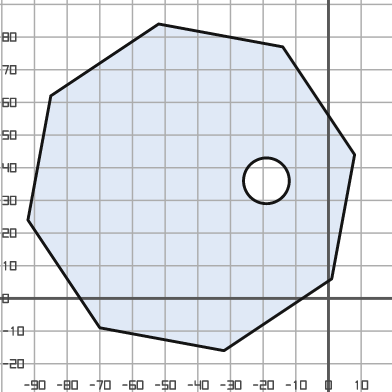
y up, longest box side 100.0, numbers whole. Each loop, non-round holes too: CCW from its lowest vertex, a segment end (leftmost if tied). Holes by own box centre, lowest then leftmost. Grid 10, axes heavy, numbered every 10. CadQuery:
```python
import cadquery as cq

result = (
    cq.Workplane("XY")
    .moveTo(-32.0, -16.0)
    .lineTo(1.0, 6.0)
    .lineTo(8.0, 44.0)
    .lineTo(-14.0, 77.0)
    .lineTo(-52.0, 84.0)
    .lineTo(-85.0, 62.0)
    .lineTo(-92.0, 24.0)
    .lineTo(-70.0, -9.0)
    .close()
    .moveTo(-19.0, 36.0)
    .circle(7.0)
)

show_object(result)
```